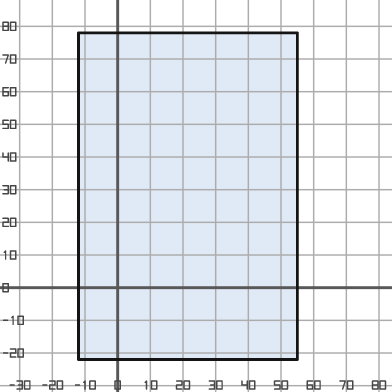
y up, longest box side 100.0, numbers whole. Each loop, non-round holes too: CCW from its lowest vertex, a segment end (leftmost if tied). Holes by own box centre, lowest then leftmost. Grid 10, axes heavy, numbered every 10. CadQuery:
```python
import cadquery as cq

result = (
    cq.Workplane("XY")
    .moveTo(-12.0, -22.0)
    .lineTo(55.0, -22.0)
    .lineTo(55.0, 78.0)
    .lineTo(-12.0, 78.0)
    .close()
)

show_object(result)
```